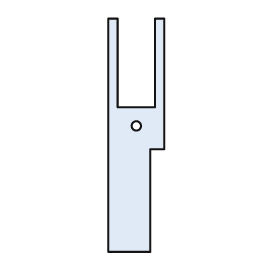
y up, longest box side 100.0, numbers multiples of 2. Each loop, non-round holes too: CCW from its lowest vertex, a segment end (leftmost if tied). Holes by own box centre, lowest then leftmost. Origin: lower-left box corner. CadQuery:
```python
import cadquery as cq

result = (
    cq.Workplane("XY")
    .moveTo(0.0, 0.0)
    .lineTo(18.0, 0.0)
    .lineTo(18.0, 44.0)
    .lineTo(24.0, 44.0)
    .lineTo(24.0, 100.0)
    .lineTo(20.0, 100.0)
    .lineTo(20.0, 62.0)
    .lineTo(4.0, 62.0)
    .lineTo(4.0, 100.0)
    .lineTo(0.0, 100.0)
    .close()
    .moveTo(12.0, 54.0)
    .circle(2.0)
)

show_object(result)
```